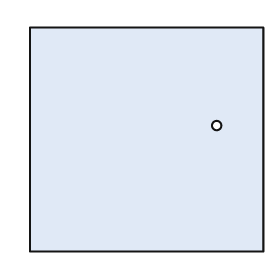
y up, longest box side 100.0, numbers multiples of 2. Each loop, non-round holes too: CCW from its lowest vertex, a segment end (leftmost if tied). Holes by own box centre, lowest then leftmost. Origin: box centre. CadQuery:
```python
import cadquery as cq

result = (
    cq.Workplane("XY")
    .moveTo(-50.0, -48.0)
    .lineTo(50.0, -48.0)
    .lineTo(50.0, 48.0)
    .lineTo(-50.0, 48.0)
    .close()
    .moveTo(30.0, 6.0)
    .circle(2.0)
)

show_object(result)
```